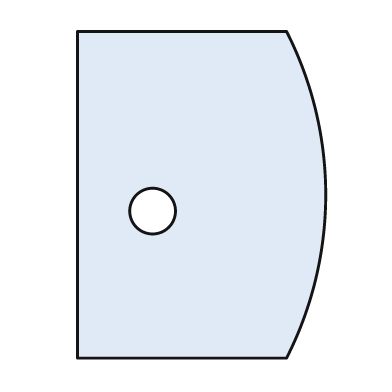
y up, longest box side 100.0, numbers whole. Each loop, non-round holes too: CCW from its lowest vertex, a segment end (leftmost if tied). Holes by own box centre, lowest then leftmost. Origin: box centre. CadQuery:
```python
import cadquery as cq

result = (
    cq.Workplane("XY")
    .moveTo(-38.0, -50.0)
    .lineTo(26.0, -50.0)
    .threePointArc((38.0, 0.0), (26.0, 50.0))
    .lineTo(-38.0, 50.0)
    .close()
    .moveTo(-15.0, -5.0)
    .circle(7.0)
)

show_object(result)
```